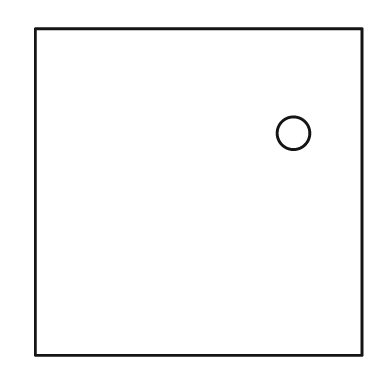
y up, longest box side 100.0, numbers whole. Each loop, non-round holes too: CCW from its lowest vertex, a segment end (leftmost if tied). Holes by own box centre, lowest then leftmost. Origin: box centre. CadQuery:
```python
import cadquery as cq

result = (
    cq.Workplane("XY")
    .moveTo(-50.0, -50.0)
    .lineTo(50.0, -50.0)
    .lineTo(50.0, 50.0)
    .lineTo(-50.0, 50.0)
    .close()
    .moveTo(29.0, 18.0)
    .circle(5.0)
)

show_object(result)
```